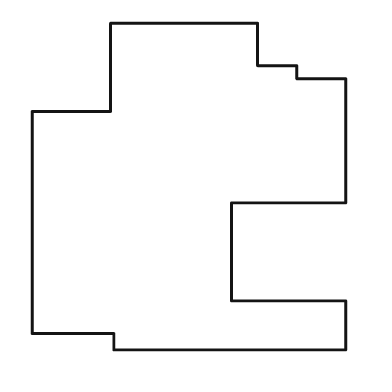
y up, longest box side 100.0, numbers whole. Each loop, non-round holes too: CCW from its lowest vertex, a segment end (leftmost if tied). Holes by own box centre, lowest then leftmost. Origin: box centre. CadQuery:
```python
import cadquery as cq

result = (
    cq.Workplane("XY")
    .moveTo(-23.0, -50.0)
    .lineTo(48.0, -50.0)
    .lineTo(48.0, -35.0)
    .lineTo(13.0, -35.0)
    .lineTo(13.0, -5.0)
    .lineTo(48.0, -5.0)
    .lineTo(48.0, 33.0)
    .lineTo(33.0, 33.0)
    .lineTo(33.0, 37.0)
    .lineTo(21.0, 37.0)
    .lineTo(21.0, 50.0)
    .lineTo(-24.0, 50.0)
    .lineTo(-24.0, 23.0)
    .lineTo(-48.0, 23.0)
    .lineTo(-48.0, -45.0)
    .lineTo(-23.0, -45.0)
    .close()
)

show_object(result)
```